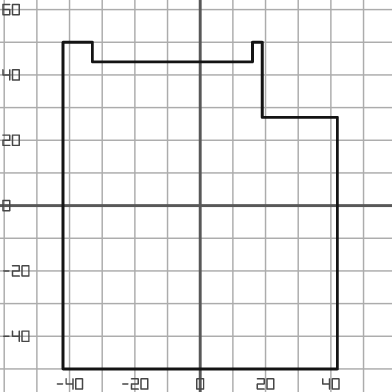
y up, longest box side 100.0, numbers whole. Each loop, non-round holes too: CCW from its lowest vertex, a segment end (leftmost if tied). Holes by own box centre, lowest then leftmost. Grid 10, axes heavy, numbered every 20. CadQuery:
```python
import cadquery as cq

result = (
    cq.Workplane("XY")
    .moveTo(-42.0, -50.0)
    .lineTo(42.0, -50.0)
    .lineTo(42.0, 27.0)
    .lineTo(19.0, 27.0)
    .lineTo(19.0, 50.0)
    .lineTo(16.0, 50.0)
    .lineTo(16.0, 44.0)
    .lineTo(-33.0, 44.0)
    .lineTo(-33.0, 50.0)
    .lineTo(-42.0, 50.0)
    .close()
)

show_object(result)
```